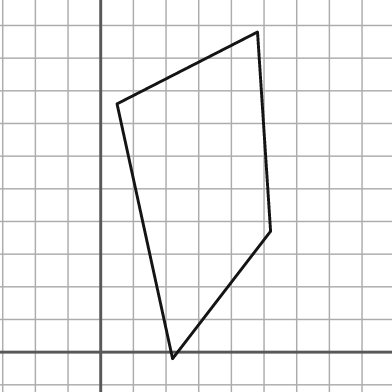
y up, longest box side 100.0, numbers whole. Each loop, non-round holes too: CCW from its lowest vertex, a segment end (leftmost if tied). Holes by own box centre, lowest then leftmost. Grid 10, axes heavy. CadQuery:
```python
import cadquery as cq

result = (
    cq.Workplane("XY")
    .moveTo(22.0, -2.0)
    .lineTo(52.0, 37.0)
    .lineTo(48.0, 98.0)
    .lineTo(5.0, 76.0)
    .close()
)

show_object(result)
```